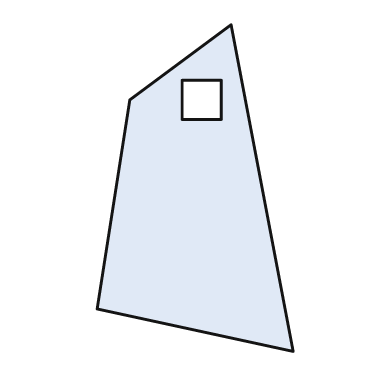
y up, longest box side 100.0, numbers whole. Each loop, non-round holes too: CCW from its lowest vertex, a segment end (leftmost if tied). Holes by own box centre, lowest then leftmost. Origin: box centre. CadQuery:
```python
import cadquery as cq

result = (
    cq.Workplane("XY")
    .moveTo(30.0, -50.0)
    .lineTo(11.0, 50.0)
    .lineTo(-20.0, 27.0)
    .lineTo(-30.0, -37.0)
    .close()
    .moveTo(-4.0, 21.0)
    .lineTo(8.0, 21.0)
    .lineTo(8.0, 33.0)
    .lineTo(-4.0, 33.0)
    .close()
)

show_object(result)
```